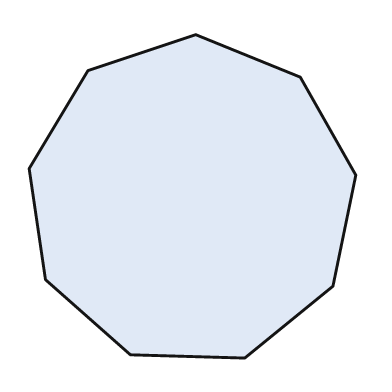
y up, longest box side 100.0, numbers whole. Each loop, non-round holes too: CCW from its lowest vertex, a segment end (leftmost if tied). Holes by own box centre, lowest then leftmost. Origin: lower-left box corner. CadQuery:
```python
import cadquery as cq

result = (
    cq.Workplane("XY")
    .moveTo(66.0, 0.0)
    .lineTo(93.0, 22.0)
    .lineTo(100.0, 56.0)
    .lineTo(83.0, 86.0)
    .lineTo(51.0, 99.0)
    .lineTo(18.0, 88.0)
    .lineTo(0.0, 58.0)
    .lineTo(5.0, 24.0)
    .lineTo(31.0, 1.0)
    .close()
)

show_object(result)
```